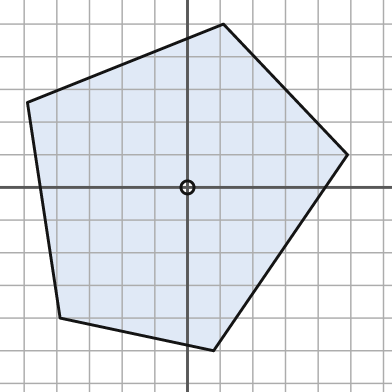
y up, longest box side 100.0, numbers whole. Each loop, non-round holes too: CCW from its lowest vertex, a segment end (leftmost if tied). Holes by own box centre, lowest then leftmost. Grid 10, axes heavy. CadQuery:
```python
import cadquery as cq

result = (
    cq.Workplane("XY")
    .moveTo(8.0, -50.0)
    .lineTo(49.0, 10.0)
    .lineTo(11.0, 50.0)
    .lineTo(-49.0, 26.0)
    .lineTo(-39.0, -40.0)
    .close()
    .moveTo(0.0, 0.0)
    .circle(2.0)
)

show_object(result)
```